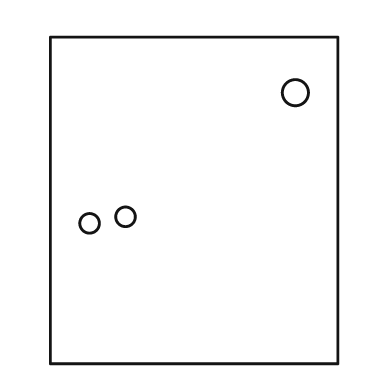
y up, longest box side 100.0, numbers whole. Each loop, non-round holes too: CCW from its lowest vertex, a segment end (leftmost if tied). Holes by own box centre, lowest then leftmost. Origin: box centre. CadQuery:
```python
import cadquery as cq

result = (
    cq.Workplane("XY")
    .moveTo(-44.0, -50.0)
    .lineTo(44.0, -50.0)
    .lineTo(44.0, 50.0)
    .lineTo(-44.0, 50.0)
    .close()
    .moveTo(-32.0, -7.0)
    .circle(3.0)
    .moveTo(-21.0, -5.0)
    .circle(3.0)
    .moveTo(31.0, 33.0)
    .circle(4.0)
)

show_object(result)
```